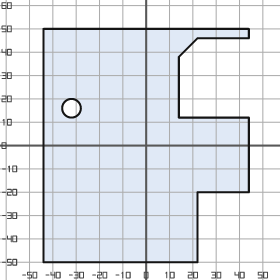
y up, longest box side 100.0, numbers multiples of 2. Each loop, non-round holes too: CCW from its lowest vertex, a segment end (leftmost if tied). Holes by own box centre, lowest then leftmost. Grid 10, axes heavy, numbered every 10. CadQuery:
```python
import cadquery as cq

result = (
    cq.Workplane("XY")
    .moveTo(-44.0, -50.0)
    .lineTo(22.0, -50.0)
    .lineTo(22.0, -20.0)
    .lineTo(44.0, -20.0)
    .lineTo(44.0, 12.0)
    .lineTo(14.0, 12.0)
    .lineTo(14.0, 38.0)
    .lineTo(22.0, 46.0)
    .lineTo(44.0, 46.0)
    .lineTo(44.0, 50.0)
    .lineTo(-44.0, 50.0)
    .close()
    .moveTo(-32.0, 16.0)
    .circle(4.0)
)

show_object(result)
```